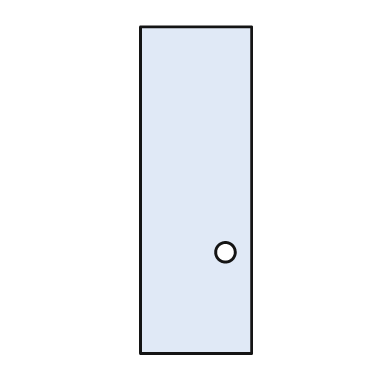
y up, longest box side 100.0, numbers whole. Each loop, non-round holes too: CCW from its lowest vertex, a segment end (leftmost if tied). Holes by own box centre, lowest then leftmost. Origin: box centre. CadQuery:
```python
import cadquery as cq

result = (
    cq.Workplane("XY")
    .moveTo(-17.0, -50.0)
    .lineTo(17.0, -50.0)
    .lineTo(17.0, 50.0)
    .lineTo(-17.0, 50.0)
    .close()
    .moveTo(9.0, -19.0)
    .circle(3.0)
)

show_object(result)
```